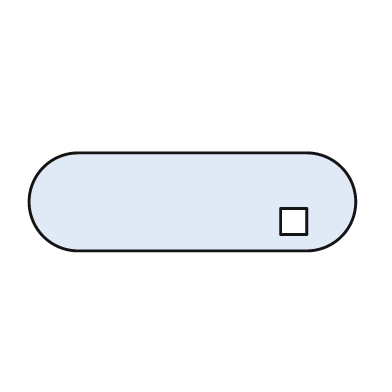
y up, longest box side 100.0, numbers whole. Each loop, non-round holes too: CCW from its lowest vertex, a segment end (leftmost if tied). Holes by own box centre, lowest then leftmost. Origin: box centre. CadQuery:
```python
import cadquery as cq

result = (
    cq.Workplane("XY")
    .moveTo(-35.0, -15.0)
    .lineTo(35.0, -15.0)
    .threePointArc((50.0, 0.0), (35.0, 15.0))
    .lineTo(-35.0, 15.0)
    .threePointArc((-50.0, 0.0), (-35.0, -15.0))
    .close()
    .moveTo(27.0, -10.0)
    .lineTo(35.0, -10.0)
    .lineTo(35.0, -2.0)
    .lineTo(27.0, -2.0)
    .close()
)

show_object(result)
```